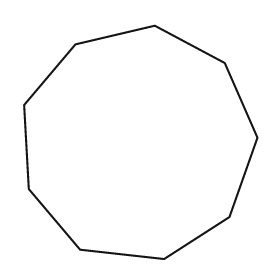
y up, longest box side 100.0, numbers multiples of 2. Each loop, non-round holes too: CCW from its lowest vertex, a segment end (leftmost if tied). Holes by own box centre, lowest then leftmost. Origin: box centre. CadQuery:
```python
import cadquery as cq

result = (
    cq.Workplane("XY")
    .moveTo(10.0, -50.0)
    .lineTo(38.0, -32.0)
    .lineTo(50.0, 2.0)
    .lineTo(36.0, 34.0)
    .lineTo(6.0, 50.0)
    .lineTo(-28.0, 42.0)
    .lineTo(-50.0, 16.0)
    .lineTo(-48.0, -20.0)
    .lineTo(-26.0, -46.0)
    .close()
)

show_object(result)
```